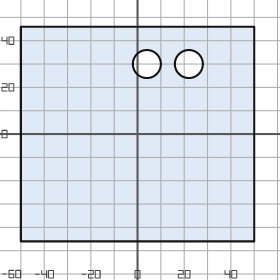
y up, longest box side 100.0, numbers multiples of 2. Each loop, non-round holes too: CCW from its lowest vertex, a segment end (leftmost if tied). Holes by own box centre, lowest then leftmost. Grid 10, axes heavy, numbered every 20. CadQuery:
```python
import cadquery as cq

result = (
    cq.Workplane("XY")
    .moveTo(-50.0, -46.0)
    .lineTo(50.0, -46.0)
    .lineTo(50.0, 46.0)
    .lineTo(-50.0, 46.0)
    .close()
    .moveTo(4.0, 30.0)
    .circle(6.0)
    .moveTo(22.0, 30.0)
    .circle(6.0)
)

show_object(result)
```